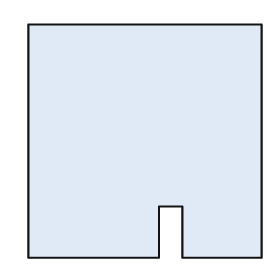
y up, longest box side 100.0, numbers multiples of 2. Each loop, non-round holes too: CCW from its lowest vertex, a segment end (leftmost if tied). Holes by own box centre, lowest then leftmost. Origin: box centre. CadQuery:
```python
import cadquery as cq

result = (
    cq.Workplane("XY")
    .moveTo(-50.0, -50.0)
    .lineTo(6.0, -50.0)
    .lineTo(6.0, -28.0)
    .lineTo(16.0, -28.0)
    .lineTo(16.0, -50.0)
    .lineTo(50.0, -50.0)
    .lineTo(50.0, 50.0)
    .lineTo(-50.0, 50.0)
    .close()
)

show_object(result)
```